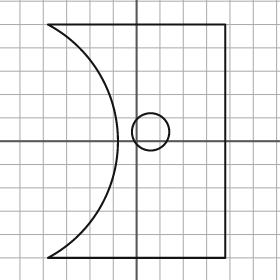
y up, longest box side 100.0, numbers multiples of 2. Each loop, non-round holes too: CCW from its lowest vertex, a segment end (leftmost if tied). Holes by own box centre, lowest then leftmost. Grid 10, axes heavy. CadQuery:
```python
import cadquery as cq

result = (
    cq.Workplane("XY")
    .moveTo(-38.0, -50.0)
    .lineTo(38.0, -50.0)
    .lineTo(38.0, 50.0)
    .lineTo(-38.0, 50.0)
    .threePointArc((-8.0, 0.0), (-38.0, -50.0))
    .close()
    .moveTo(6.0, 4.0)
    .circle(8.0)
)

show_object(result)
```